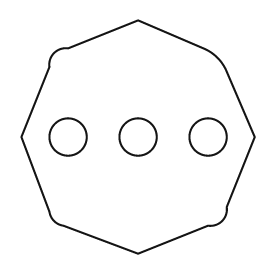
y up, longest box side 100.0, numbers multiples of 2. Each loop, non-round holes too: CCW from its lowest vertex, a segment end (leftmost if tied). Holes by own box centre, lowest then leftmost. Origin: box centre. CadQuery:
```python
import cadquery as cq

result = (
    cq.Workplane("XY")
    .moveTo(0.0, -50.0)
    .lineTo(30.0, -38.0)
    .threePointArc((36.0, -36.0), (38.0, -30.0))
    .lineTo(50.0, 0.0)
    .lineTo(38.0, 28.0)
    .threePointArc((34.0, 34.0), (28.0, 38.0))
    .lineTo(0.0, 50.0)
    .lineTo(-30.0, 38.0)
    .threePointArc((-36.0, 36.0), (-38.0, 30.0))
    .lineTo(-50.0, 0.0)
    .lineTo(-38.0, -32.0)
    .threePointArc((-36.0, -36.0), (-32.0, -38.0))
    .close()
    .moveTo(-30.0, 0.0)
    .circle(8.0)
    .moveTo(0.0, 0.0)
    .circle(8.0)
    .moveTo(30.0, 0.0)
    .circle(8.0)
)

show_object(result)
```